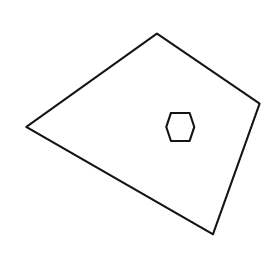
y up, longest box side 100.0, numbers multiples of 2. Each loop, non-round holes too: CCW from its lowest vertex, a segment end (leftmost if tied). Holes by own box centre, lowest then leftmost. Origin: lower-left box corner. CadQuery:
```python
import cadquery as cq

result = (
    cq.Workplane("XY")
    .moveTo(80.0, 0.0)
    .lineTo(100.0, 56.0)
    .lineTo(56.0, 86.0)
    .lineTo(0.0, 46.0)
    .close()
    .moveTo(62.0, 40.0)
    .lineTo(70.0, 40.0)
    .lineTo(72.0, 46.0)
    .lineTo(70.0, 52.0)
    .lineTo(62.0, 52.0)
    .lineTo(60.0, 46.0)
    .close()
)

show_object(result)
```